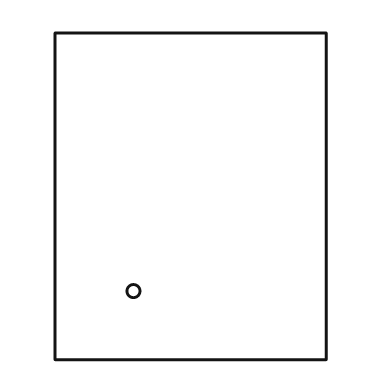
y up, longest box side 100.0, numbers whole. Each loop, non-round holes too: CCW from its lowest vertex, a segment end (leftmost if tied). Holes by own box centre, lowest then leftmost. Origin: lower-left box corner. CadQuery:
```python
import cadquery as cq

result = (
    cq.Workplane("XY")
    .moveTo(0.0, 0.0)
    .lineTo(83.0, 0.0)
    .lineTo(83.0, 100.0)
    .lineTo(0.0, 100.0)
    .close()
    .moveTo(24.0, 21.0)
    .circle(2.0)
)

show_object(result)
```